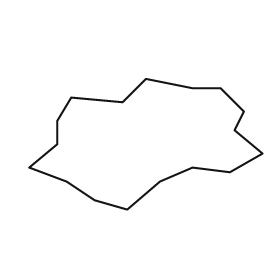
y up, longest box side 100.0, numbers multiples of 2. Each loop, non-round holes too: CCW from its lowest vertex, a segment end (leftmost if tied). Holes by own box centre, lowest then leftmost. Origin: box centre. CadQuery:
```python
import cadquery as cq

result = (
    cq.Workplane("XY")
    .moveTo(-8.0, -28.0)
    .lineTo(6.0, -16.0)
    .lineTo(20.0, -10.0)
    .lineTo(36.0, -12.0)
    .lineTo(50.0, -4.0)
    .lineTo(38.0, 6.0)
    .lineTo(42.0, 14.0)
    .lineTo(32.0, 24.0)
    .lineTo(20.0, 24.0)
    .lineTo(0.0, 28.0)
    .lineTo(-10.0, 18.0)
    .lineTo(-32.0, 20.0)
    .lineTo(-38.0, 10.0)
    .lineTo(-38.0, 0.0)
    .lineTo(-50.0, -10.0)
    .lineTo(-34.0, -16.0)
    .lineTo(-22.0, -24.0)
    .close()
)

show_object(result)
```